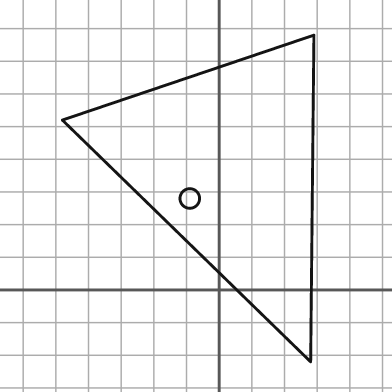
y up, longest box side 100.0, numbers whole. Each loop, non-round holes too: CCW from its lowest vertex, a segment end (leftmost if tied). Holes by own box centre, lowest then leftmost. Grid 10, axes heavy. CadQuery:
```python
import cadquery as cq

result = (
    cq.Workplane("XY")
    .moveTo(28.0, -22.0)
    .lineTo(29.0, 78.0)
    .lineTo(-48.0, 52.0)
    .close()
    .moveTo(-9.0, 28.0)
    .circle(3.0)
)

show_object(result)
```